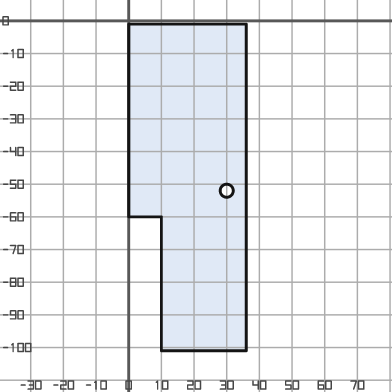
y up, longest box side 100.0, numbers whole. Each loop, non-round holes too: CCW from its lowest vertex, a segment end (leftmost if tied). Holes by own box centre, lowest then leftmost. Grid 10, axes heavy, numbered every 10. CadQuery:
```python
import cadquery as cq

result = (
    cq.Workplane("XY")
    .moveTo(10.0, -101.0)
    .lineTo(36.0, -101.0)
    .lineTo(36.0, -1.0)
    .lineTo(0.0, -1.0)
    .lineTo(0.0, -60.0)
    .lineTo(10.0, -60.0)
    .close()
    .moveTo(30.0, -52.0)
    .circle(2.0)
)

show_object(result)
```